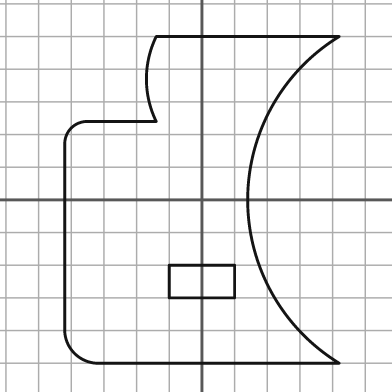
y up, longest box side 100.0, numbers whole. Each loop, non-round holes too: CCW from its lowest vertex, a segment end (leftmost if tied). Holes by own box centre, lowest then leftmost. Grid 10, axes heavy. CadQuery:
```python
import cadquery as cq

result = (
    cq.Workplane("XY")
    .moveTo(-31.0, -50.0)
    .lineTo(42.0, -50.0)
    .threePointArc((14.0, 0.0), (42.0, 50.0))
    .lineTo(-14.0, 50.0)
    .threePointArc((-17.0, 37.0), (-14.0, 24.0))
    .lineTo(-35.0, 24.0)
    .threePointArc((-40.0, 22.0), (-42.0, 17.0))
    .lineTo(-42.0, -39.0)
    .threePointArc((-39.0, -47.0), (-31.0, -50.0))
    .close()
    .moveTo(-10.0, -30.0)
    .lineTo(10.0, -30.0)
    .lineTo(10.0, -20.0)
    .lineTo(-10.0, -20.0)
    .close()
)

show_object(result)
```